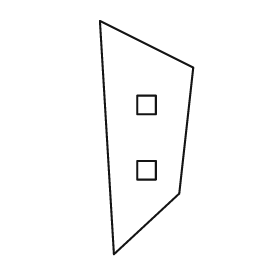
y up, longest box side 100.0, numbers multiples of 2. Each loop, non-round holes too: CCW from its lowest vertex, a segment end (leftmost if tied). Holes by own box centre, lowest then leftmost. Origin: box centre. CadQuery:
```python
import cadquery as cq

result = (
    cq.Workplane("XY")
    .moveTo(-14.0, -50.0)
    .lineTo(14.0, -24.0)
    .lineTo(20.0, 30.0)
    .lineTo(-20.0, 50.0)
    .close()
    .moveTo(-4.0, -18.0)
    .lineTo(4.0, -18.0)
    .lineTo(4.0, -10.0)
    .lineTo(-4.0, -10.0)
    .close()
    .moveTo(-4.0, 10.0)
    .lineTo(4.0, 10.0)
    .lineTo(4.0, 18.0)
    .lineTo(-4.0, 18.0)
    .close()
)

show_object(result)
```